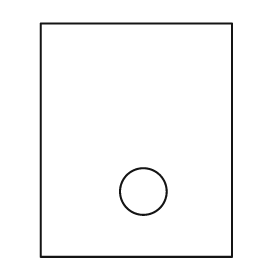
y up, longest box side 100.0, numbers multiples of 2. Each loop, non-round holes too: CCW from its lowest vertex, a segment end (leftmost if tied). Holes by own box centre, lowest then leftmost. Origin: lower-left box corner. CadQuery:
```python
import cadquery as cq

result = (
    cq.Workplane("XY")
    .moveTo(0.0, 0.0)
    .lineTo(82.0, 0.0)
    .lineTo(82.0, 100.0)
    .lineTo(0.0, 100.0)
    .close()
    .moveTo(44.0, 28.0)
    .circle(10.0)
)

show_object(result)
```